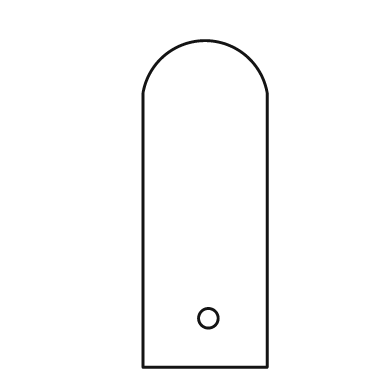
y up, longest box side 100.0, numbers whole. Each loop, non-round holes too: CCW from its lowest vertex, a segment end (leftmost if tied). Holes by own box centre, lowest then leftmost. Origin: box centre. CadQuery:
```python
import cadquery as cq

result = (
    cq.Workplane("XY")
    .moveTo(-19.0, -50.0)
    .lineTo(19.0, -50.0)
    .lineTo(19.0, 34.0)
    .threePointArc((0.0, 50.0), (-19.0, 34.0))
    .close()
    .moveTo(1.0, -35.0)
    .circle(3.0)
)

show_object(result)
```